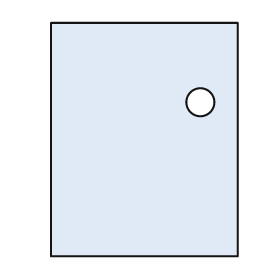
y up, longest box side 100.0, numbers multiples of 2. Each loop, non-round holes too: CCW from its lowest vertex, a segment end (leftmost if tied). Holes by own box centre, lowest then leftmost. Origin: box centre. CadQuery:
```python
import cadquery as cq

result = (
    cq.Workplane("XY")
    .moveTo(-40.0, -50.0)
    .lineTo(40.0, -50.0)
    .lineTo(40.0, 50.0)
    .lineTo(-40.0, 50.0)
    .close()
    .moveTo(24.0, 16.0)
    .circle(6.0)
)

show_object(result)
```